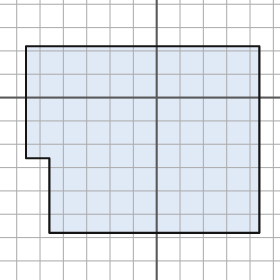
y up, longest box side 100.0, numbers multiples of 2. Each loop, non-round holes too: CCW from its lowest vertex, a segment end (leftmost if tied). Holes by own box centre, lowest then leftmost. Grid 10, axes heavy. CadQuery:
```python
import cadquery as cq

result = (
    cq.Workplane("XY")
    .moveTo(-46.0, -58.0)
    .lineTo(44.0, -58.0)
    .lineTo(44.0, 22.0)
    .lineTo(-56.0, 22.0)
    .lineTo(-56.0, -26.0)
    .lineTo(-46.0, -26.0)
    .close()
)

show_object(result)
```